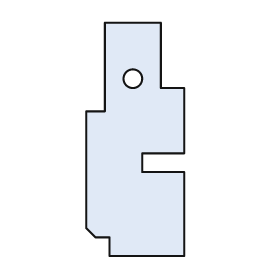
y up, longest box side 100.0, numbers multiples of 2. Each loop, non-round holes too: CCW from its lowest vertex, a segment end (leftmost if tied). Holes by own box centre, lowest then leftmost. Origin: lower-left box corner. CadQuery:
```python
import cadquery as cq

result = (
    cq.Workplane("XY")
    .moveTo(10.0, 0.0)
    .lineTo(42.0, 0.0)
    .lineTo(42.0, 36.0)
    .lineTo(24.0, 36.0)
    .lineTo(24.0, 44.0)
    .lineTo(42.0, 44.0)
    .lineTo(42.0, 72.0)
    .lineTo(32.0, 72.0)
    .lineTo(32.0, 100.0)
    .lineTo(8.0, 100.0)
    .lineTo(8.0, 62.0)
    .lineTo(0.0, 62.0)
    .lineTo(0.0, 12.0)
    .lineTo(4.0, 8.0)
    .lineTo(10.0, 8.0)
    .close()
    .moveTo(20.0, 76.0)
    .circle(4.0)
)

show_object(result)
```